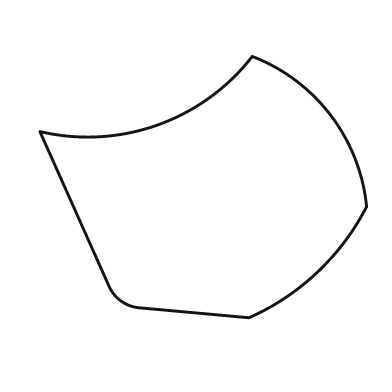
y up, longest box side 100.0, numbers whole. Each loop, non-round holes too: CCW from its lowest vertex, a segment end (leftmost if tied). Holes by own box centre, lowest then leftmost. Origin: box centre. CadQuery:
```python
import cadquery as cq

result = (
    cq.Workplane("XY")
    .moveTo(14.0, -40.0)
    .threePointArc((35.0, -26.0), (50.0, -6.0))
    .threePointArc((39.0, 22.0), (15.0, 40.0))
    .threePointArc((-14.0, 19.0), (-50.0, 17.0))
    .lineTo(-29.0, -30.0)
    .threePointArc((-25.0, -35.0), (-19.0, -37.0))
    .close()
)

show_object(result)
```